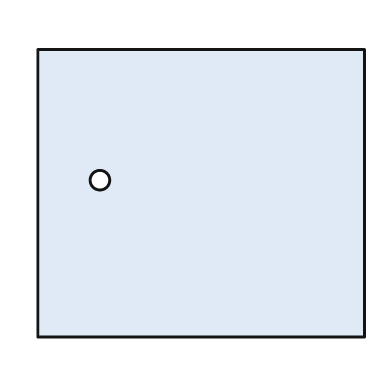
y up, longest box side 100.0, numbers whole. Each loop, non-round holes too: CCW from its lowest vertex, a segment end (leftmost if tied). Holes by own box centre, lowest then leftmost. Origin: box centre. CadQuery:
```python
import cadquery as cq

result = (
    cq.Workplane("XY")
    .moveTo(-50.0, -44.0)
    .lineTo(50.0, -44.0)
    .lineTo(50.0, 44.0)
    .lineTo(-50.0, 44.0)
    .close()
    .moveTo(-31.0, 4.0)
    .circle(3.0)
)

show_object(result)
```